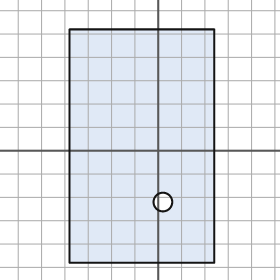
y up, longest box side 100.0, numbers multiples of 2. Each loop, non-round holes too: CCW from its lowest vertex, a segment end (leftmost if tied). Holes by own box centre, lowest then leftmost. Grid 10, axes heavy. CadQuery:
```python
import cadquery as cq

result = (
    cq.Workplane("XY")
    .moveTo(-38.0, -48.0)
    .lineTo(24.0, -48.0)
    .lineTo(24.0, 52.0)
    .lineTo(-38.0, 52.0)
    .close()
    .moveTo(2.0, -22.0)
    .circle(4.0)
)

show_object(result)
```